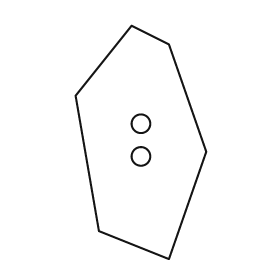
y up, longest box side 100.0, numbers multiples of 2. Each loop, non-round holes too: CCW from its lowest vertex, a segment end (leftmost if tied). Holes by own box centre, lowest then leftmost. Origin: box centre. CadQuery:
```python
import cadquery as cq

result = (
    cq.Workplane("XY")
    .moveTo(12.0, -50.0)
    .lineTo(28.0, -4.0)
    .lineTo(12.0, 42.0)
    .lineTo(-4.0, 50.0)
    .lineTo(-28.0, 20.0)
    .lineTo(-18.0, -38.0)
    .close()
    .moveTo(0.0, -6.0)
    .circle(4.0)
    .moveTo(0.0, 8.0)
    .circle(4.0)
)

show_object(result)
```